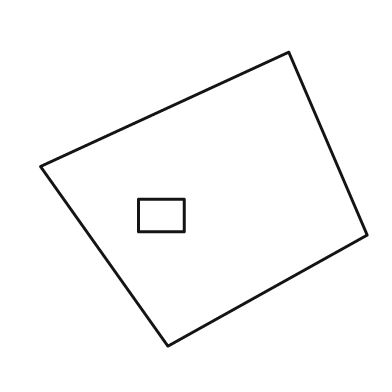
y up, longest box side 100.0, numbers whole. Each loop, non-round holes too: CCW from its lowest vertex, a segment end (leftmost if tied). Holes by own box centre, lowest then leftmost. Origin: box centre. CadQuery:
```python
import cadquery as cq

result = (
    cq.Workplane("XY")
    .moveTo(-11.0, -45.0)
    .lineTo(50.0, -11.0)
    .lineTo(26.0, 45.0)
    .lineTo(-50.0, 10.0)
    .close()
    .moveTo(-20.0, -10.0)
    .lineTo(-6.0, -10.0)
    .lineTo(-6.0, 0.0)
    .lineTo(-20.0, 0.0)
    .close()
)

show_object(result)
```